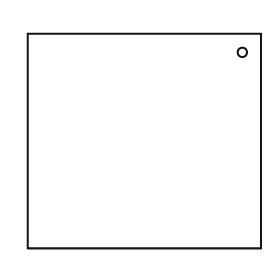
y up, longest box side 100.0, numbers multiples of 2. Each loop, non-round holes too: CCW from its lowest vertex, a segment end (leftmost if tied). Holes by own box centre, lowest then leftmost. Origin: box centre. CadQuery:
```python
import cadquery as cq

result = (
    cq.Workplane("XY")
    .moveTo(-50.0, -46.0)
    .lineTo(50.0, -46.0)
    .lineTo(50.0, 46.0)
    .lineTo(-50.0, 46.0)
    .close()
    .moveTo(42.0, 38.0)
    .circle(2.0)
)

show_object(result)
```